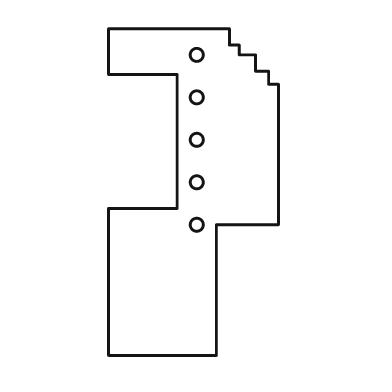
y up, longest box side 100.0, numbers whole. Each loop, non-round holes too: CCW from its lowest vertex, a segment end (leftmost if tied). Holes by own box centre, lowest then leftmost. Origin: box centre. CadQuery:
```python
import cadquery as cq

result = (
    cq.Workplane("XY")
    .moveTo(-26.0, -50.0)
    .lineTo(7.0, -50.0)
    .lineTo(7.0, -10.0)
    .lineTo(26.0, -10.0)
    .lineTo(26.0, 33.0)
    .lineTo(23.0, 33.0)
    .lineTo(23.0, 37.0)
    .lineTo(19.0, 37.0)
    .lineTo(19.0, 42.0)
    .lineTo(14.0, 42.0)
    .lineTo(14.0, 45.0)
    .lineTo(11.0, 45.0)
    .lineTo(11.0, 50.0)
    .lineTo(-26.0, 50.0)
    .lineTo(-26.0, 36.0)
    .lineTo(-5.0, 36.0)
    .lineTo(-5.0, -5.0)
    .lineTo(-26.0, -5.0)
    .close()
    .moveTo(1.0, -10.0)
    .circle(2.0)
    .moveTo(1.0, 3.0)
    .circle(2.0)
    .moveTo(1.0, 16.0)
    .circle(2.0)
    .moveTo(1.0, 29.0)
    .circle(2.0)
    .moveTo(1.0, 42.0)
    .circle(2.0)
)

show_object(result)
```